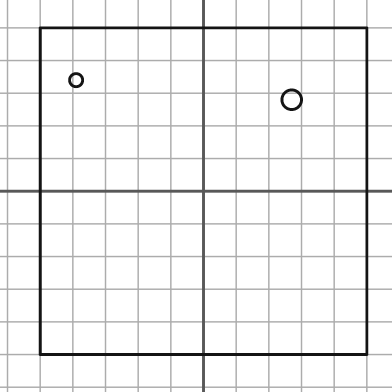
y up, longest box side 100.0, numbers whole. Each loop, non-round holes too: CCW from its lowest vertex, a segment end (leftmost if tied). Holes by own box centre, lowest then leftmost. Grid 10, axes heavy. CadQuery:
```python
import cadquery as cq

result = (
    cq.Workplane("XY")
    .moveTo(-50.0, -50.0)
    .lineTo(50.0, -50.0)
    .lineTo(50.0, 50.0)
    .lineTo(-50.0, 50.0)
    .close()
    .moveTo(27.0, 28.0)
    .circle(3.0)
    .moveTo(-39.0, 34.0)
    .circle(2.0)
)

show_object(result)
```